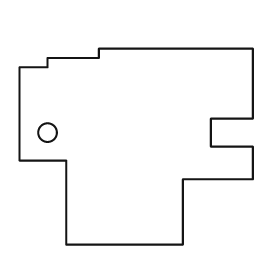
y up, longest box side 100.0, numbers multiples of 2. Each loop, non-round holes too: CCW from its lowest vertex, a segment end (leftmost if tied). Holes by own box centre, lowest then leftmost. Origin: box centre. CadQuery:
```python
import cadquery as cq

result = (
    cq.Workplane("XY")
    .moveTo(-30.0, -42.0)
    .lineTo(20.0, -42.0)
    .lineTo(20.0, -14.0)
    .lineTo(50.0, -14.0)
    .lineTo(50.0, 0.0)
    .lineTo(32.0, 0.0)
    .lineTo(32.0, 12.0)
    .lineTo(50.0, 12.0)
    .lineTo(50.0, 42.0)
    .lineTo(-16.0, 42.0)
    .lineTo(-16.0, 38.0)
    .lineTo(-38.0, 38.0)
    .lineTo(-38.0, 34.0)
    .lineTo(-50.0, 34.0)
    .lineTo(-50.0, -6.0)
    .lineTo(-30.0, -6.0)
    .close()
    .moveTo(-38.0, 6.0)
    .circle(4.0)
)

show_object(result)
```